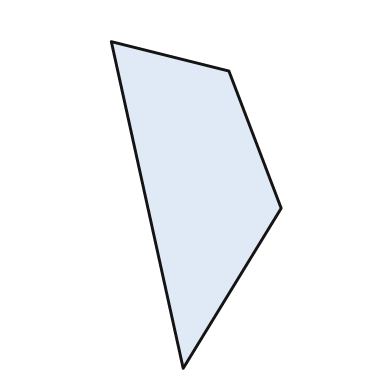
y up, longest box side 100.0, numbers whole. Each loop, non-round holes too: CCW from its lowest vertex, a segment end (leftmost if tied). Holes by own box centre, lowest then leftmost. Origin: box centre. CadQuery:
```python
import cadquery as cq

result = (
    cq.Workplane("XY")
    .moveTo(-4.0, -50.0)
    .lineTo(26.0, -1.0)
    .lineTo(10.0, 41.0)
    .lineTo(-26.0, 50.0)
    .close()
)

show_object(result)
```